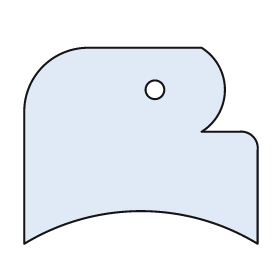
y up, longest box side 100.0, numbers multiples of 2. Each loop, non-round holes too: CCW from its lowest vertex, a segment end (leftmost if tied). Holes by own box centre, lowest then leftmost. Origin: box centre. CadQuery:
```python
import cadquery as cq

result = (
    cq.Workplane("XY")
    .moveTo(-50.0, -42.0)
    .threePointArc((0.0, -28.0), (50.0, -42.0))
    .lineTo(50.0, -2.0)
    .threePointArc((48.0, 4.0), (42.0, 6.0))
    .lineTo(26.0, 6.0)
    .threePointArc((36.0, 24.0), (26.0, 42.0))
    .lineTo(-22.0, 42.0)
    .threePointArc((-42.0, 34.0), (-50.0, 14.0))
    .close()
    .moveTo(6.0, 24.0)
    .circle(4.0)
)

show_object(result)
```